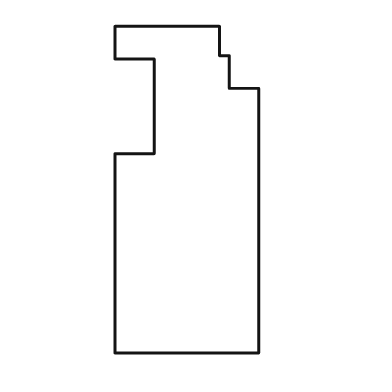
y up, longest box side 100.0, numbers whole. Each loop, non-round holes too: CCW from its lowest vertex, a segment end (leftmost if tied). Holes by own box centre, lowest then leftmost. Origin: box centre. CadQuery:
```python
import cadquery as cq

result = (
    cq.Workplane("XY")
    .moveTo(-22.0, -50.0)
    .lineTo(22.0, -50.0)
    .lineTo(22.0, 31.0)
    .lineTo(13.0, 31.0)
    .lineTo(13.0, 41.0)
    .lineTo(10.0, 41.0)
    .lineTo(10.0, 50.0)
    .lineTo(-22.0, 50.0)
    .lineTo(-22.0, 40.0)
    .lineTo(-10.0, 40.0)
    .lineTo(-10.0, 11.0)
    .lineTo(-22.0, 11.0)
    .close()
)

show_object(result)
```